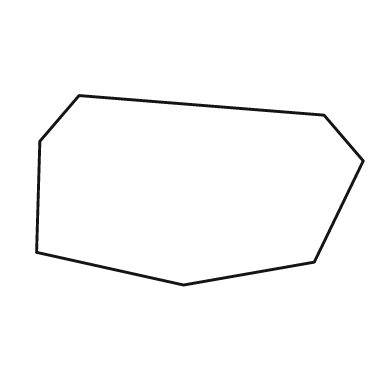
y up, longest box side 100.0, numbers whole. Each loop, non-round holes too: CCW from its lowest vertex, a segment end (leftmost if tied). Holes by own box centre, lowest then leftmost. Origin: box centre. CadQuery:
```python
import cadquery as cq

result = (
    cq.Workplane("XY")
    .moveTo(-5.0, -29.0)
    .lineTo(35.0, -22.0)
    .lineTo(50.0, 9.0)
    .lineTo(38.0, 23.0)
    .lineTo(-37.0, 29.0)
    .lineTo(-49.0, 15.0)
    .lineTo(-50.0, -19.0)
    .close()
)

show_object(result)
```